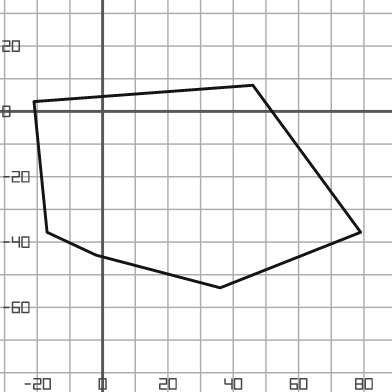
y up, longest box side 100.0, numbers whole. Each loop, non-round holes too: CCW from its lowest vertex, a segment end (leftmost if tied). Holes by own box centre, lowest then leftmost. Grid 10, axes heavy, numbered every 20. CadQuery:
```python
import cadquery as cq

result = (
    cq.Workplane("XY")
    .moveTo(36.0, -54.0)
    .lineTo(79.0, -37.0)
    .lineTo(46.0, 8.0)
    .lineTo(-21.0, 3.0)
    .lineTo(-17.0, -37.0)
    .lineTo(-2.0, -44.0)
    .close()
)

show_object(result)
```